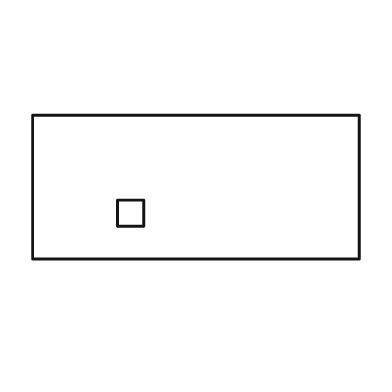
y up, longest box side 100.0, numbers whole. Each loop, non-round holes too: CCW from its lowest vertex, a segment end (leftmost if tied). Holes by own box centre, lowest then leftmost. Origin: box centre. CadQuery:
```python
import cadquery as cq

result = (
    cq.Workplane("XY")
    .moveTo(-50.0, -22.0)
    .lineTo(50.0, -22.0)
    .lineTo(50.0, 22.0)
    .lineTo(-50.0, 22.0)
    .close()
    .moveTo(-24.0, -12.0)
    .lineTo(-16.0, -12.0)
    .lineTo(-16.0, -4.0)
    .lineTo(-24.0, -4.0)
    .close()
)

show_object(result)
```